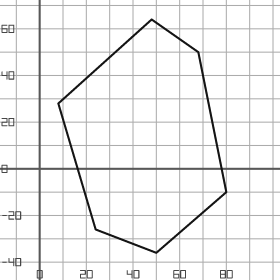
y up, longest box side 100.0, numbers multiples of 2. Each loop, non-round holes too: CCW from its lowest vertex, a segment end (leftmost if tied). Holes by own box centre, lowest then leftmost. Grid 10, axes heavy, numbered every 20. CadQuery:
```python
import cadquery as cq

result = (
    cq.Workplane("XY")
    .moveTo(50.0, -36.0)
    .lineTo(80.0, -10.0)
    .lineTo(68.0, 50.0)
    .lineTo(48.0, 64.0)
    .lineTo(8.0, 28.0)
    .lineTo(24.0, -26.0)
    .close()
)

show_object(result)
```